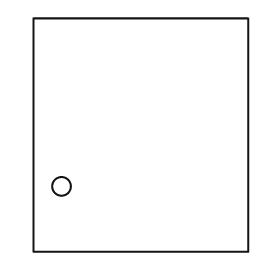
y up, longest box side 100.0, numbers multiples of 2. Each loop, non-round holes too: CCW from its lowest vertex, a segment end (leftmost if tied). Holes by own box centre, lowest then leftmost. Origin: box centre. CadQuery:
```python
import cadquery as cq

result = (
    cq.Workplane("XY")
    .moveTo(-46.0, -50.0)
    .lineTo(46.0, -50.0)
    .lineTo(46.0, 50.0)
    .lineTo(-46.0, 50.0)
    .close()
    .moveTo(-34.0, -22.0)
    .circle(4.0)
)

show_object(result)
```